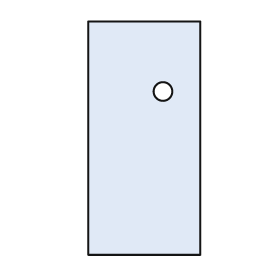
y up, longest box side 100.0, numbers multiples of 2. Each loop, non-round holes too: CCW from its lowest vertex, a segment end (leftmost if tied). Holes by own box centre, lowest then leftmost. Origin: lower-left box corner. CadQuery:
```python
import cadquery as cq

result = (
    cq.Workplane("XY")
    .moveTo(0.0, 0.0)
    .lineTo(48.0, 0.0)
    .lineTo(48.0, 100.0)
    .lineTo(0.0, 100.0)
    .close()
    .moveTo(32.0, 70.0)
    .circle(4.0)
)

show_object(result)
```